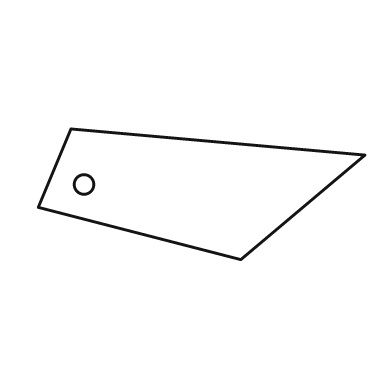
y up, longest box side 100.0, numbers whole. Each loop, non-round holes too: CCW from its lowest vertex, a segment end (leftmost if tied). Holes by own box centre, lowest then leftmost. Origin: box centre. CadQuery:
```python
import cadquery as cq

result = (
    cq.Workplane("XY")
    .moveTo(12.0, -20.0)
    .lineTo(50.0, 12.0)
    .lineTo(-40.0, 20.0)
    .lineTo(-50.0, -4.0)
    .close()
    .moveTo(-36.0, 3.0)
    .circle(3.0)
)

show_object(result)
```